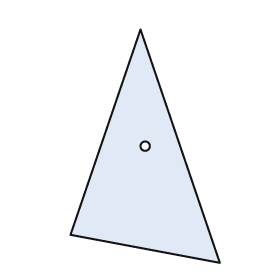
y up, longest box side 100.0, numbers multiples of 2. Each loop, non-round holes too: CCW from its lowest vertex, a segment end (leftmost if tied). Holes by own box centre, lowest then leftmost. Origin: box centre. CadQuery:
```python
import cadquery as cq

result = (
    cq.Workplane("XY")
    .moveTo(32.0, -50.0)
    .lineTo(-2.0, 50.0)
    .lineTo(-32.0, -38.0)
    .close()
    .moveTo(0.0, 0.0)
    .circle(2.0)
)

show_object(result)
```